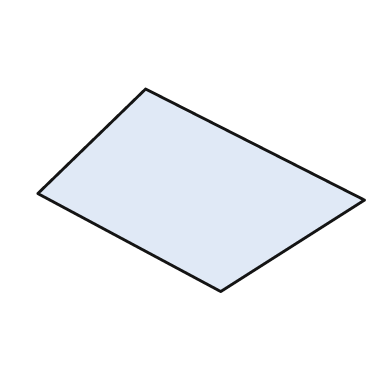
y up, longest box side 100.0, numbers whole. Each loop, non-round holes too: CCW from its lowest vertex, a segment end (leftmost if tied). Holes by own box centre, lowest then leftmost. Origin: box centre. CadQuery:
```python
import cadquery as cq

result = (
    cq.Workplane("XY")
    .moveTo(6.0, -31.0)
    .lineTo(50.0, -3.0)
    .lineTo(-17.0, 31.0)
    .lineTo(-50.0, -1.0)
    .close()
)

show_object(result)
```